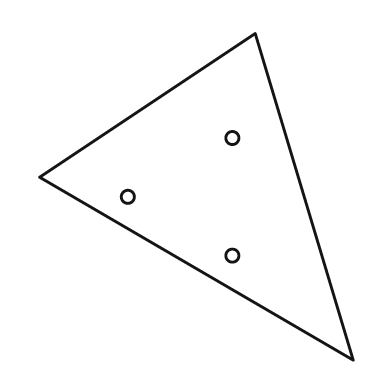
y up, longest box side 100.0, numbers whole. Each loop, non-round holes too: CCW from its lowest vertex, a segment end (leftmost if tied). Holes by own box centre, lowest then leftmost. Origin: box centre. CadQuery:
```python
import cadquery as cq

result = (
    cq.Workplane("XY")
    .moveTo(48.0, -50.0)
    .lineTo(18.0, 50.0)
    .lineTo(-48.0, 6.0)
    .close()
    .moveTo(11.0, -18.0)
    .circle(2.0)
    .moveTo(-21.0, 0.0)
    .circle(2.0)
    .moveTo(11.0, 18.0)
    .circle(2.0)
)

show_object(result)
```